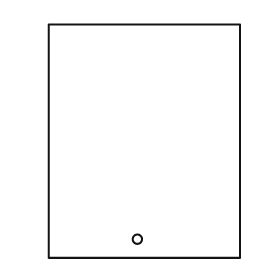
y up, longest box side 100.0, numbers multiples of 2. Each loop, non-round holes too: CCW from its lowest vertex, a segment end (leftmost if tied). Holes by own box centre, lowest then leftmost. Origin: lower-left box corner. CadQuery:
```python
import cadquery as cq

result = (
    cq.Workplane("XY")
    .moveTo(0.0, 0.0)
    .lineTo(82.0, 0.0)
    .lineTo(82.0, 100.0)
    .lineTo(0.0, 100.0)
    .close()
    .moveTo(38.0, 8.0)
    .circle(2.0)
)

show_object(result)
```